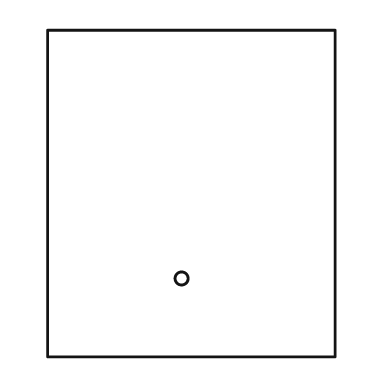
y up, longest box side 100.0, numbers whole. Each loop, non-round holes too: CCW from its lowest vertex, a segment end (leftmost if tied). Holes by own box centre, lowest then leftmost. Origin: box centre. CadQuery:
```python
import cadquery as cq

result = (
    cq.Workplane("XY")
    .moveTo(-44.0, -50.0)
    .lineTo(44.0, -50.0)
    .lineTo(44.0, 50.0)
    .lineTo(-44.0, 50.0)
    .close()
    .moveTo(-3.0, -26.0)
    .circle(2.0)
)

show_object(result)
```